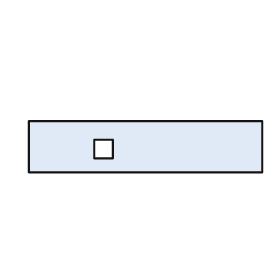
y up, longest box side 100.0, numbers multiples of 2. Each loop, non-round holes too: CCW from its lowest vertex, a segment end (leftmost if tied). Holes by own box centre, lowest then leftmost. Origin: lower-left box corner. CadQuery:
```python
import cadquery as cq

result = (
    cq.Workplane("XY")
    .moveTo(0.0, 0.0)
    .lineTo(100.0, 0.0)
    .lineTo(100.0, 22.0)
    .lineTo(0.0, 22.0)
    .close()
    .moveTo(28.0, 6.0)
    .lineTo(36.0, 6.0)
    .lineTo(36.0, 14.0)
    .lineTo(28.0, 14.0)
    .close()
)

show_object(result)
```